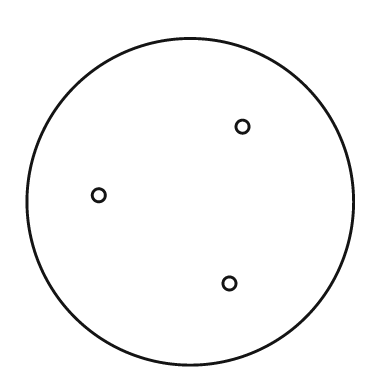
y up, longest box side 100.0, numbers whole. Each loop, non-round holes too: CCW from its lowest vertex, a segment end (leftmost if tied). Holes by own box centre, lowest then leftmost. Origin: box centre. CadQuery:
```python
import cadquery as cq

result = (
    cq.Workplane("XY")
    .moveTo(0.0, 0.0)
    .circle(50.0)
    .moveTo(12.0, -25.0)
    .circle(2.0)
    .moveTo(-28.0, 2.0)
    .circle(2.0)
    .moveTo(16.0, 23.0)
    .circle(2.0)
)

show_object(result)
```